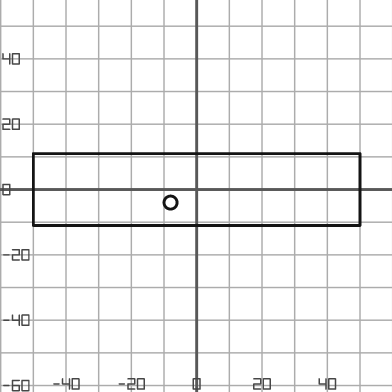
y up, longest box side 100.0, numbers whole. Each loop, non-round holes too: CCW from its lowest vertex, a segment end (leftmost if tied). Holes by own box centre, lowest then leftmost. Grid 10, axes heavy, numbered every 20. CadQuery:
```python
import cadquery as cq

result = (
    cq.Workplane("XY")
    .moveTo(-50.0, -11.0)
    .lineTo(50.0, -11.0)
    .lineTo(50.0, 11.0)
    .lineTo(-50.0, 11.0)
    .close()
    .moveTo(-8.0, -4.0)
    .circle(2.0)
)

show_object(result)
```